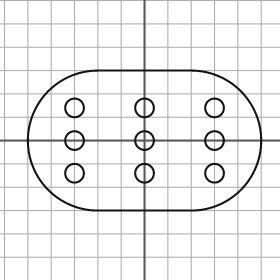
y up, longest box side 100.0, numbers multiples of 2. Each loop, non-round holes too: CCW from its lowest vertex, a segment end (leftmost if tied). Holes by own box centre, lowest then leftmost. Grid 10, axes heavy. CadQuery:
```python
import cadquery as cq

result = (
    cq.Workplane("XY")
    .moveTo(-20.0, -30.0)
    .lineTo(20.0, -30.0)
    .threePointArc((50.0, 0.0), (20.0, 30.0))
    .lineTo(-20.0, 30.0)
    .threePointArc((-50.0, 0.0), (-20.0, -30.0))
    .close()
    .moveTo(-30.0, -14.0)
    .circle(4.0)
    .moveTo(0.0, -14.0)
    .circle(4.0)
    .moveTo(30.0, -14.0)
    .circle(4.0)
    .moveTo(-30.0, 0.0)
    .circle(4.0)
    .moveTo(0.0, 0.0)
    .circle(4.0)
    .moveTo(30.0, 0.0)
    .circle(4.0)
    .moveTo(-30.0, 14.0)
    .circle(4.0)
    .moveTo(0.0, 14.0)
    .circle(4.0)
    .moveTo(30.0, 14.0)
    .circle(4.0)
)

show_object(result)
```